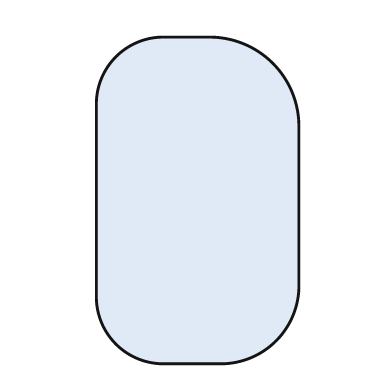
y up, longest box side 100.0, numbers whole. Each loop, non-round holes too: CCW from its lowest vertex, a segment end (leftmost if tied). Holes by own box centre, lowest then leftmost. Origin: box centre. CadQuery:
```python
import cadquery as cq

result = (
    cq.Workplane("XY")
    .moveTo(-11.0, -50.0)
    .lineTo(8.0, -50.0)
    .threePointArc((24.0, -43.0), (31.0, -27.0))
    .lineTo(31.0, 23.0)
    .threePointArc((23.0, 42.0), (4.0, 50.0))
    .lineTo(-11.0, 50.0)
    .threePointArc((-25.0, 44.0), (-31.0, 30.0))
    .lineTo(-31.0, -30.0)
    .threePointArc((-25.0, -44.0), (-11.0, -50.0))
    .close()
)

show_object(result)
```